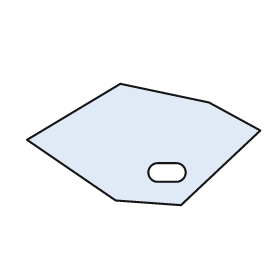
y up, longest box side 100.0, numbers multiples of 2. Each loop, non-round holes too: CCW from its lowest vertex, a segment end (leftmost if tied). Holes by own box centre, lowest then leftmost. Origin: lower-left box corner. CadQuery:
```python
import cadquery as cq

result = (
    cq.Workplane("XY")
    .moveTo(66.0, 0.0)
    .lineTo(100.0, 32.0)
    .lineTo(78.0, 44.0)
    .lineTo(40.0, 52.0)
    .lineTo(0.0, 28.0)
    .lineTo(38.0, 2.0)
    .close()
    .moveTo(56.0, 10.0)
    .lineTo(64.0, 10.0)
    .threePointArc((68.0, 14.0), (64.0, 18.0))
    .lineTo(56.0, 18.0)
    .threePointArc((52.0, 14.0), (56.0, 10.0))
    .close()
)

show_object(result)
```